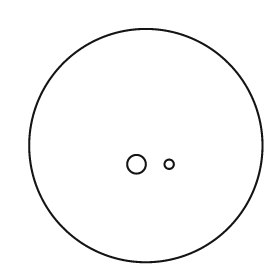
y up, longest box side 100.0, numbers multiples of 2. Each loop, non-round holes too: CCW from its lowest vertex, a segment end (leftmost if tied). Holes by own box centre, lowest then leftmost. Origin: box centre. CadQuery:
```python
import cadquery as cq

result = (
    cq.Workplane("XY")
    .moveTo(0.0, 0.0)
    .circle(50.0)
    .moveTo(-4.0, -8.0)
    .circle(4.0)
    .moveTo(10.0, -8.0)
    .circle(2.0)
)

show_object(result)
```